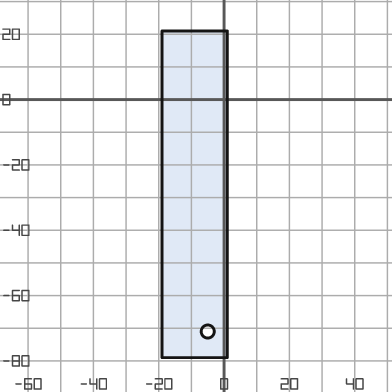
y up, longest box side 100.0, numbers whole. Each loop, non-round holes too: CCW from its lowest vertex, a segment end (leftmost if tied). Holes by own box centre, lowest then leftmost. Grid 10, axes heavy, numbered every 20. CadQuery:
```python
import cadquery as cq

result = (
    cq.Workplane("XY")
    .moveTo(-19.0, -79.0)
    .lineTo(1.0, -79.0)
    .lineTo(1.0, 21.0)
    .lineTo(-19.0, 21.0)
    .close()
    .moveTo(-5.0, -71.0)
    .circle(2.0)
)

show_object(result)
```